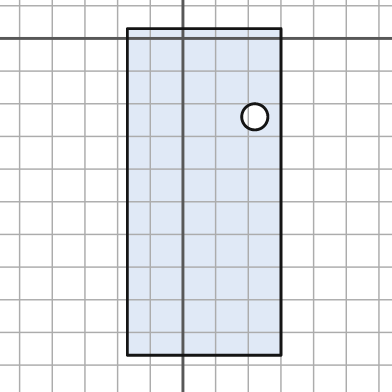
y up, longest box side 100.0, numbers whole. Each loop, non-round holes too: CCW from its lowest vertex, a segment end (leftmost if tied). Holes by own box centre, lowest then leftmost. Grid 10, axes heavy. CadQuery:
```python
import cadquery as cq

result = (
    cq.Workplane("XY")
    .moveTo(-17.0, -97.0)
    .lineTo(30.0, -97.0)
    .lineTo(30.0, 3.0)
    .lineTo(-17.0, 3.0)
    .close()
    .moveTo(22.0, -24.0)
    .circle(4.0)
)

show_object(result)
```